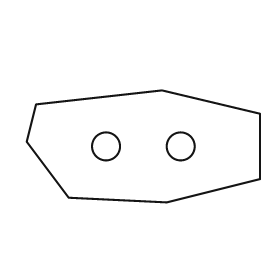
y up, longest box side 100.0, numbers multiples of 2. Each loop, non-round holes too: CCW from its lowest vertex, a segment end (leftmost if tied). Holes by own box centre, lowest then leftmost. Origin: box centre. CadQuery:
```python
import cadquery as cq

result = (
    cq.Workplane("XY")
    .moveTo(10.0, -24.0)
    .lineTo(50.0, -14.0)
    .lineTo(50.0, 14.0)
    .lineTo(8.0, 24.0)
    .lineTo(-46.0, 18.0)
    .lineTo(-50.0, 2.0)
    .lineTo(-32.0, -22.0)
    .close()
    .moveTo(-16.0, 0.0)
    .circle(6.0)
    .moveTo(16.0, 0.0)
    .circle(6.0)
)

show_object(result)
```